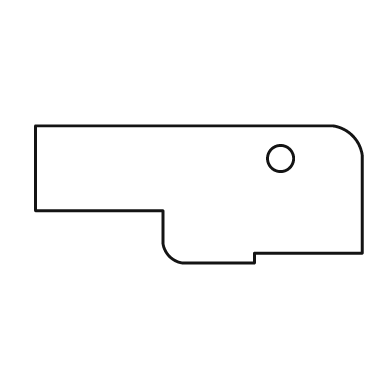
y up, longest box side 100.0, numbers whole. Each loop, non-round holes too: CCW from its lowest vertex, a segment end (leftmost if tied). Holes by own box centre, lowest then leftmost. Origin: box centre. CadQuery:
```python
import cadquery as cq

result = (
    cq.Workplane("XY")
    .moveTo(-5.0, -21.0)
    .lineTo(17.0, -21.0)
    .lineTo(17.0, -18.0)
    .lineTo(50.0, -18.0)
    .lineTo(50.0, 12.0)
    .threePointArc((47.0, 18.0), (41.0, 21.0))
    .lineTo(-50.0, 21.0)
    .lineTo(-50.0, -5.0)
    .lineTo(-11.0, -5.0)
    .lineTo(-11.0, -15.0)
    .threePointArc((-9.0, -19.0), (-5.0, -21.0))
    .close()
    .moveTo(25.0, 11.0)
    .circle(4.0)
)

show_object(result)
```